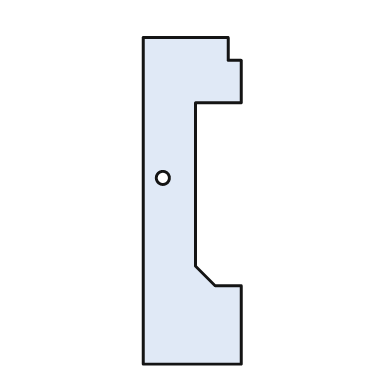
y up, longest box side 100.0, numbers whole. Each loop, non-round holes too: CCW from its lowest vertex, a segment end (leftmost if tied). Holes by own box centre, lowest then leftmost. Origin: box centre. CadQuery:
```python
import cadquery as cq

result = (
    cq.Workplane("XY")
    .moveTo(-15.0, -50.0)
    .lineTo(15.0, -50.0)
    .lineTo(15.0, -26.0)
    .lineTo(7.0, -26.0)
    .lineTo(1.0, -20.0)
    .lineTo(1.0, 30.0)
    .lineTo(15.0, 30.0)
    .lineTo(15.0, 43.0)
    .lineTo(11.0, 43.0)
    .lineTo(11.0, 50.0)
    .lineTo(-15.0, 50.0)
    .close()
    .moveTo(-9.0, 7.0)
    .circle(2.0)
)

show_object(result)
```